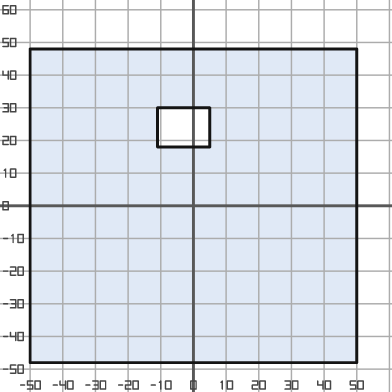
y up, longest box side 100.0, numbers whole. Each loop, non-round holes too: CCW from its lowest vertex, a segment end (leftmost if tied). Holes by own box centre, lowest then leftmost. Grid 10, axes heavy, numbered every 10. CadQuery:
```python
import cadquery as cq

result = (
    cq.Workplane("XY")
    .moveTo(-50.0, -48.0)
    .lineTo(50.0, -48.0)
    .lineTo(50.0, 48.0)
    .lineTo(-50.0, 48.0)
    .close()
    .moveTo(-11.0, 18.0)
    .lineTo(5.0, 18.0)
    .lineTo(5.0, 30.0)
    .lineTo(-11.0, 30.0)
    .close()
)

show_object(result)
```